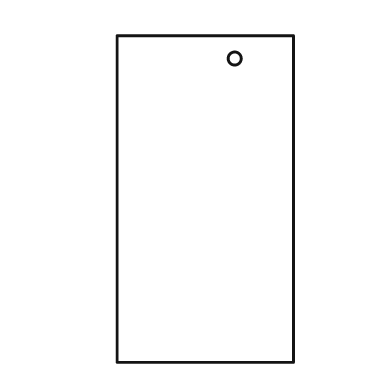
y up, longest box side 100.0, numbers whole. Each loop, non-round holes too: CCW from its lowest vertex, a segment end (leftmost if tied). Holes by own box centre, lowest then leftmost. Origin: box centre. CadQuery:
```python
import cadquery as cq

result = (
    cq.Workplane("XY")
    .moveTo(-27.0, -50.0)
    .lineTo(27.0, -50.0)
    .lineTo(27.0, 50.0)
    .lineTo(-27.0, 50.0)
    .close()
    .moveTo(9.0, 43.0)
    .circle(2.0)
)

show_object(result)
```